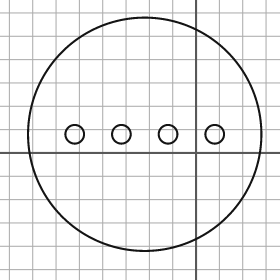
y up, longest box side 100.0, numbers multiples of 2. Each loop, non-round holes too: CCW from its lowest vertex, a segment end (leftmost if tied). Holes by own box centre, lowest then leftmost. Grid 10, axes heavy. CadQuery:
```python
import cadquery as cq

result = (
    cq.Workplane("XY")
    .moveTo(-22.0, 8.0)
    .circle(50.0)
    .moveTo(-52.0, 8.0)
    .circle(4.0)
    .moveTo(-32.0, 8.0)
    .circle(4.0)
    .moveTo(-12.0, 8.0)
    .circle(4.0)
    .moveTo(8.0, 8.0)
    .circle(4.0)
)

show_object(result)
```